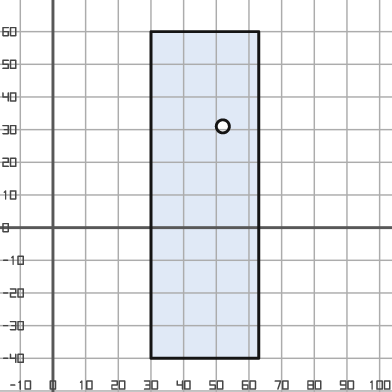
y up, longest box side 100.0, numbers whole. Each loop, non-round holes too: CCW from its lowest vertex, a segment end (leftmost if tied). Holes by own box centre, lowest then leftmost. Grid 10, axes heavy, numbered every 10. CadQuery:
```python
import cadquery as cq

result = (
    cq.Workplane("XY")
    .moveTo(30.0, -40.0)
    .lineTo(63.0, -40.0)
    .lineTo(63.0, 60.0)
    .lineTo(30.0, 60.0)
    .close()
    .moveTo(52.0, 31.0)
    .circle(2.0)
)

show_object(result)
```